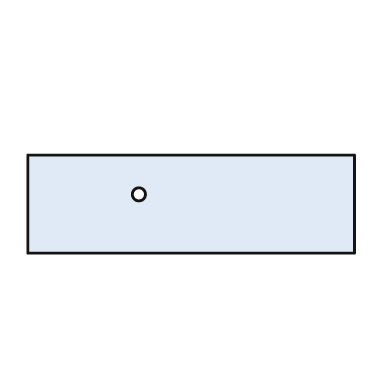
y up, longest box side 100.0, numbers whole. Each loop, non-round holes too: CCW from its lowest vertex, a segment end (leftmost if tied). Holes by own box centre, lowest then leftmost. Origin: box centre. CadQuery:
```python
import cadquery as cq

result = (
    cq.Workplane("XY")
    .moveTo(-50.0, -15.0)
    .lineTo(50.0, -15.0)
    .lineTo(50.0, 15.0)
    .lineTo(-50.0, 15.0)
    .close()
    .moveTo(-16.0, 3.0)
    .circle(2.0)
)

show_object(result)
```